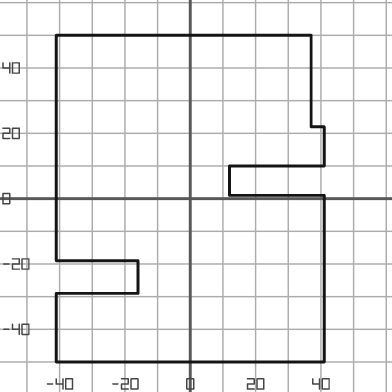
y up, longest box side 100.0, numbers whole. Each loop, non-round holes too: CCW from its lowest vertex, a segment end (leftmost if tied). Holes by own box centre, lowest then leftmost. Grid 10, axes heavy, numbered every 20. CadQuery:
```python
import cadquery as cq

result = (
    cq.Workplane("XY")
    .moveTo(-41.0, -50.0)
    .lineTo(41.0, -50.0)
    .lineTo(41.0, 1.0)
    .lineTo(12.0, 1.0)
    .lineTo(12.0, 10.0)
    .lineTo(41.0, 10.0)
    .lineTo(41.0, 22.0)
    .lineTo(37.0, 22.0)
    .lineTo(37.0, 50.0)
    .lineTo(-41.0, 50.0)
    .lineTo(-41.0, -19.0)
    .lineTo(-16.0, -19.0)
    .lineTo(-16.0, -29.0)
    .lineTo(-41.0, -29.0)
    .close()
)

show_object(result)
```